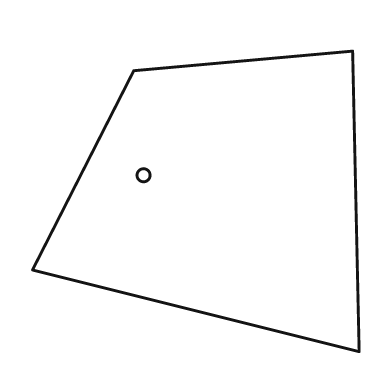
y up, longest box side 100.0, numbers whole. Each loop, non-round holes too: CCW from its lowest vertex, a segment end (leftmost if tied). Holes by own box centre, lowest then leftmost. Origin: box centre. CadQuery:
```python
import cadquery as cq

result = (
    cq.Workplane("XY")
    .moveTo(50.0, -46.0)
    .lineTo(48.0, 46.0)
    .lineTo(-19.0, 40.0)
    .lineTo(-50.0, -21.0)
    .close()
    .moveTo(-16.0, 8.0)
    .circle(2.0)
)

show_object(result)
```